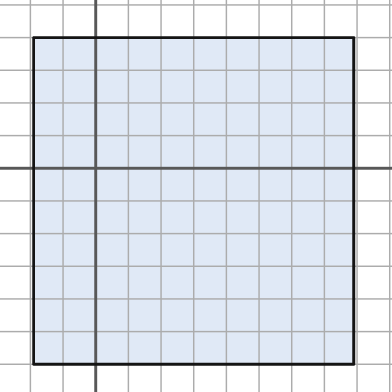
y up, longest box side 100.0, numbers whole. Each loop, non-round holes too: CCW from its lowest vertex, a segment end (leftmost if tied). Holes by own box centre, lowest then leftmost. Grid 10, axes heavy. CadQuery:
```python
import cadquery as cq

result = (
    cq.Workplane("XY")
    .moveTo(-19.0, -60.0)
    .lineTo(79.0, -60.0)
    .lineTo(79.0, 40.0)
    .lineTo(-19.0, 40.0)
    .close()
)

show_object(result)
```